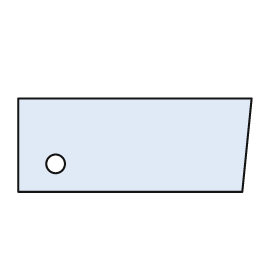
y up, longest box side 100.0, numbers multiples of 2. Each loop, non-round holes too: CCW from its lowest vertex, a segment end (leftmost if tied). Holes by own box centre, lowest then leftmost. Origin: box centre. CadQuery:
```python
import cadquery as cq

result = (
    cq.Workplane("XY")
    .moveTo(-50.0, -20.0)
    .lineTo(46.0, -20.0)
    .lineTo(50.0, 20.0)
    .lineTo(-50.0, 20.0)
    .close()
    .moveTo(-34.0, -8.0)
    .circle(4.0)
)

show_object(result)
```